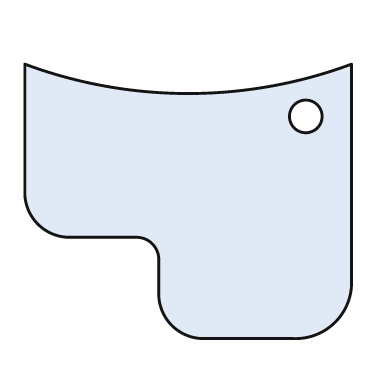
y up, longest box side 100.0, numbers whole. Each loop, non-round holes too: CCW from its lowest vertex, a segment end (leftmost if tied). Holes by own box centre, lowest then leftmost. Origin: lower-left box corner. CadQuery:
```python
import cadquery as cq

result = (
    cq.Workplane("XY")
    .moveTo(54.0, 0.0)
    .lineTo(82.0, 0.0)
    .threePointArc((95.0, 5.0), (100.0, 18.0))
    .lineTo(100.0, 84.0)
    .threePointArc((50.0, 75.0), (0.0, 84.0))
    .lineTo(0.0, 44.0)
    .threePointArc((4.0, 35.0), (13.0, 31.0))
    .lineTo(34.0, 31.0)
    .threePointArc((39.0, 29.0), (41.0, 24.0))
    .lineTo(41.0, 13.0)
    .threePointArc((45.0, 4.0), (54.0, 0.0))
    .close()
    .moveTo(86.0, 68.0)
    .circle(5.0)
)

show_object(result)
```